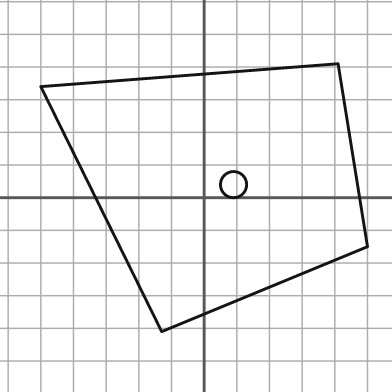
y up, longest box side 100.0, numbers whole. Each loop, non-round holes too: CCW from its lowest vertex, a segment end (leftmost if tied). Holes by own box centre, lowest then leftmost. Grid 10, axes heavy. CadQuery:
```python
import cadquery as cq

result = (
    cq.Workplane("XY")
    .moveTo(-13.0, -41.0)
    .lineTo(50.0, -15.0)
    .lineTo(41.0, 41.0)
    .lineTo(-50.0, 34.0)
    .close()
    .moveTo(9.0, 4.0)
    .circle(4.0)
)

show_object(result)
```